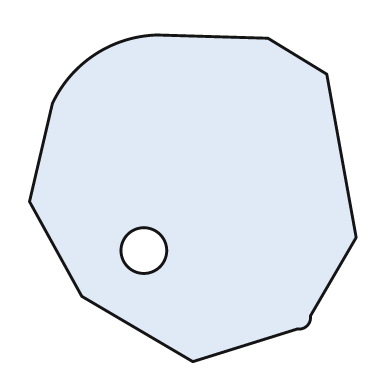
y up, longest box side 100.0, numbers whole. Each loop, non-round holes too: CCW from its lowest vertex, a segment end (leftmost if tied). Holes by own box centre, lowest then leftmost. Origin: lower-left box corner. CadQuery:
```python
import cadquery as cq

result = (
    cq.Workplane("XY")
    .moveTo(50.0, 0.0)
    .lineTo(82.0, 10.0)
    .threePointArc((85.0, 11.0), (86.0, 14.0))
    .lineTo(100.0, 38.0)
    .lineTo(91.0, 88.0)
    .lineTo(73.0, 99.0)
    .lineTo(39.0, 100.0)
    .threePointArc((20.0, 94.0), (7.0, 79.0))
    .lineTo(0.0, 49.0)
    .lineTo(16.0, 20.0)
    .close()
    .moveTo(35.0, 34.0)
    .circle(7.0)
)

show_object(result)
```